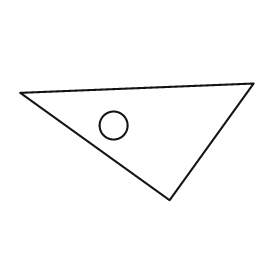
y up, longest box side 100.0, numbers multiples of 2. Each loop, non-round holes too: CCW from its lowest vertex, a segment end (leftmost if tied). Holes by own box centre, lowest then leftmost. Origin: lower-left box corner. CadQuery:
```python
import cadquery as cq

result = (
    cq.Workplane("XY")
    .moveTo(64.0, 0.0)
    .lineTo(100.0, 50.0)
    .lineTo(0.0, 46.0)
    .close()
    .moveTo(40.0, 32.0)
    .circle(6.0)
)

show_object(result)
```